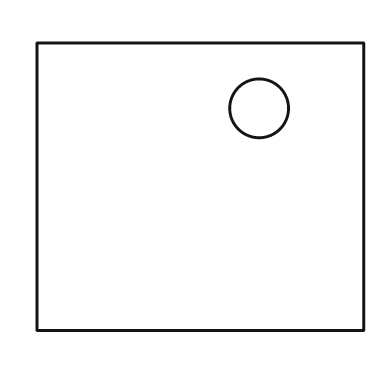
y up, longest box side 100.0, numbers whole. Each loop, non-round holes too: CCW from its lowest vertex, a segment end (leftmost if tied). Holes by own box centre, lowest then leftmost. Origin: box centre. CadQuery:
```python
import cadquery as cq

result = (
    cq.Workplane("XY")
    .moveTo(-50.0, -44.0)
    .lineTo(50.0, -44.0)
    .lineTo(50.0, 44.0)
    .lineTo(-50.0, 44.0)
    .close()
    .moveTo(18.0, 24.0)
    .circle(9.0)
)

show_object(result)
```